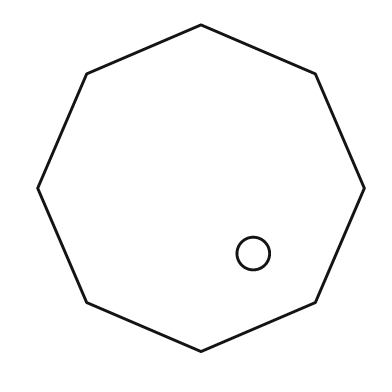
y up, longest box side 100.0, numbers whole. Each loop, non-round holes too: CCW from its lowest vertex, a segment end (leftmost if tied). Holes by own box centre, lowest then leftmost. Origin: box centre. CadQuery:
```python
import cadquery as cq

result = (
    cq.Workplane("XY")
    .moveTo(0.0, -50.0)
    .lineTo(35.0, -35.0)
    .lineTo(50.0, 0.0)
    .lineTo(35.0, 35.0)
    .lineTo(0.0, 50.0)
    .lineTo(-35.0, 35.0)
    .lineTo(-50.0, 0.0)
    .lineTo(-35.0, -35.0)
    .close()
    .moveTo(16.0, -20.0)
    .circle(5.0)
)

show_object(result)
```